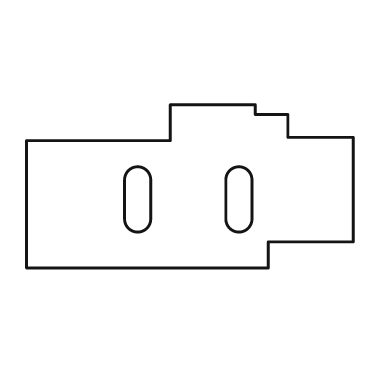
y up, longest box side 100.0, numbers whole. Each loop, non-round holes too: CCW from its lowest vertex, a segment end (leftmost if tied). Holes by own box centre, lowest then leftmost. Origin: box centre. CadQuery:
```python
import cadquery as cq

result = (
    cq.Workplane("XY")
    .moveTo(-50.0, -25.0)
    .lineTo(24.0, -25.0)
    .lineTo(24.0, -17.0)
    .lineTo(50.0, -17.0)
    .lineTo(50.0, 15.0)
    .lineTo(30.0, 15.0)
    .lineTo(30.0, 22.0)
    .lineTo(20.0, 22.0)
    .lineTo(20.0, 25.0)
    .lineTo(-6.0, 25.0)
    .lineTo(-6.0, 14.0)
    .lineTo(-50.0, 14.0)
    .close()
    .moveTo(-20.0, -10.0)
    .threePointArc((-16.0, -14.0), (-12.0, -10.0))
    .lineTo(-12.0, 2.0)
    .threePointArc((-16.0, 6.0), (-20.0, 2.0))
    .close()
    .moveTo(11.0, -10.0)
    .threePointArc((15.0, -14.0), (19.0, -10.0))
    .lineTo(19.0, 2.0)
    .threePointArc((15.0, 6.0), (11.0, 2.0))
    .close()
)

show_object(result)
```